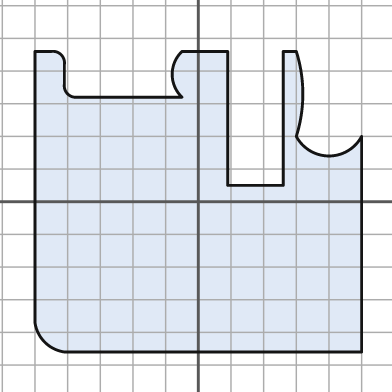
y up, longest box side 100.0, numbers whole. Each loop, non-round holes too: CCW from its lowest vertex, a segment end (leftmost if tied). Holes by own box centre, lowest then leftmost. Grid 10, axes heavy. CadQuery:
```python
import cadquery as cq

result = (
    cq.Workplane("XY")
    .moveTo(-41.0, -46.0)
    .lineTo(50.0, -46.0)
    .lineTo(50.0, 20.0)
    .threePointArc((40.0, 14.0), (30.0, 20.0))
    .threePointArc((32.0, 33.0), (30.0, 46.0))
    .lineTo(26.0, 46.0)
    .lineTo(26.0, 5.0)
    .lineTo(9.0, 5.0)
    .lineTo(9.0, 46.0)
    .lineTo(-5.0, 46.0)
    .threePointArc((-8.0, 39.0), (-5.0, 32.0))
    .lineTo(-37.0, 32.0)
    .threePointArc((-40.0, 33.0), (-41.0, 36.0))
    .lineTo(-41.0, 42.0)
    .threePointArc((-42.0, 45.0), (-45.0, 46.0))
    .lineTo(-50.0, 46.0)
    .lineTo(-50.0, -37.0)
    .threePointArc((-47.0, -43.0), (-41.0, -46.0))
    .close()
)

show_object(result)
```